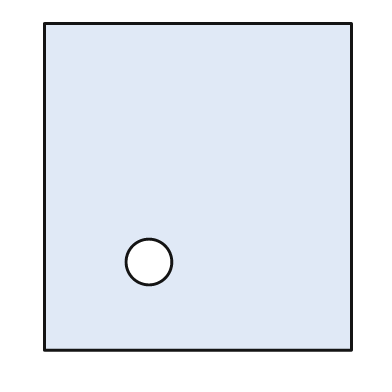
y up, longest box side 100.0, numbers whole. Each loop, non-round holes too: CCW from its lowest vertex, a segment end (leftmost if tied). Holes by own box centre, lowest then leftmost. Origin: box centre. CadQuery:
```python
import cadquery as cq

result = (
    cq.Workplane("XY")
    .moveTo(-47.0, -50.0)
    .lineTo(47.0, -50.0)
    .lineTo(47.0, 50.0)
    .lineTo(-47.0, 50.0)
    .close()
    .moveTo(-15.0, -23.0)
    .circle(7.0)
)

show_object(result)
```